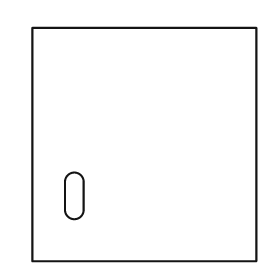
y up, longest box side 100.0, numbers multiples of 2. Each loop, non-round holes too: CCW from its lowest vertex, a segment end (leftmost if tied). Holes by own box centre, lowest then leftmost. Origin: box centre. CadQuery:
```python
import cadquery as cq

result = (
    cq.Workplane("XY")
    .moveTo(-48.0, -50.0)
    .lineTo(48.0, -50.0)
    .lineTo(48.0, 50.0)
    .lineTo(-48.0, 50.0)
    .close()
    .moveTo(-34.0, -28.0)
    .threePointArc((-30.0, -32.0), (-26.0, -28.0))
    .lineTo(-26.0, -16.0)
    .threePointArc((-30.0, -12.0), (-34.0, -16.0))
    .close()
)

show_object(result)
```